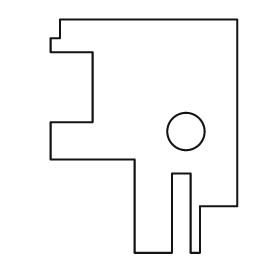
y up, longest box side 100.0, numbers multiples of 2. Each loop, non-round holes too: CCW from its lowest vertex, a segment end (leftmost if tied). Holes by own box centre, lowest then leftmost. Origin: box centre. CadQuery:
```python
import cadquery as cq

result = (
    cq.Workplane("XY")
    .moveTo(-4.0, -50.0)
    .lineTo(12.0, -50.0)
    .lineTo(12.0, -16.0)
    .lineTo(20.0, -16.0)
    .lineTo(20.0, -50.0)
    .lineTo(24.0, -50.0)
    .lineTo(24.0, -30.0)
    .lineTo(40.0, -30.0)
    .lineTo(40.0, 50.0)
    .lineTo(-36.0, 50.0)
    .lineTo(-36.0, 42.0)
    .lineTo(-40.0, 42.0)
    .lineTo(-40.0, 36.0)
    .lineTo(-22.0, 36.0)
    .lineTo(-22.0, 6.0)
    .lineTo(-40.0, 6.0)
    .lineTo(-40.0, -10.0)
    .lineTo(-4.0, -10.0)
    .close()
    .moveTo(18.0, 2.0)
    .circle(8.0)
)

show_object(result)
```